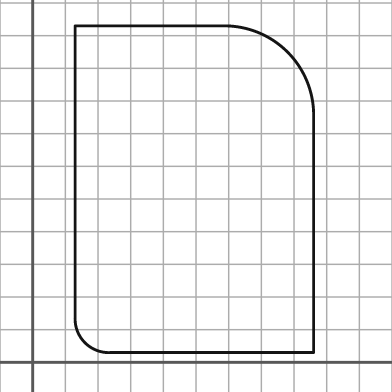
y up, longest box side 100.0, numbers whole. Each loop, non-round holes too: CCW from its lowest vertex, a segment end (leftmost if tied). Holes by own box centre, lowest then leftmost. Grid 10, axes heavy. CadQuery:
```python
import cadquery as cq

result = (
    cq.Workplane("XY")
    .moveTo(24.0, 3.0)
    .lineTo(86.0, 3.0)
    .lineTo(86.0, 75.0)
    .threePointArc((78.0, 95.0), (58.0, 103.0))
    .lineTo(13.0, 103.0)
    .lineTo(13.0, 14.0)
    .threePointArc((16.0, 6.0), (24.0, 3.0))
    .close()
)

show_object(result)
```